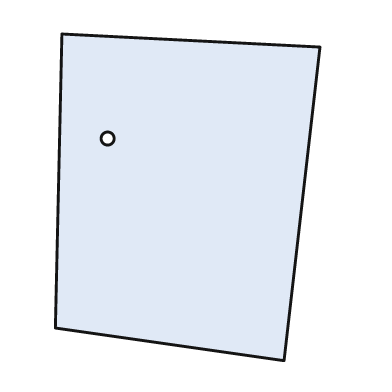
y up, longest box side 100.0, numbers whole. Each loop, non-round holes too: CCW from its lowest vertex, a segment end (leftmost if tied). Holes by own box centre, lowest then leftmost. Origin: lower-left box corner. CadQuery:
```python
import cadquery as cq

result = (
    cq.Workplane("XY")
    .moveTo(70.0, 0.0)
    .lineTo(81.0, 96.0)
    .lineTo(2.0, 100.0)
    .lineTo(0.0, 10.0)
    .close()
    .moveTo(16.0, 68.0)
    .circle(2.0)
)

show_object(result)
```